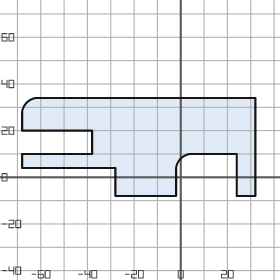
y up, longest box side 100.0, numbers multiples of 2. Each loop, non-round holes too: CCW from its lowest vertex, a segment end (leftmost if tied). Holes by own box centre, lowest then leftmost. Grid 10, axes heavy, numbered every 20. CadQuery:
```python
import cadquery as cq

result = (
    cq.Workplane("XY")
    .moveTo(-28.0, -8.0)
    .lineTo(-2.0, -8.0)
    .lineTo(-2.0, 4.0)
    .threePointArc((0.0, 8.0), (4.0, 10.0))
    .lineTo(24.0, 10.0)
    .lineTo(24.0, -8.0)
    .lineTo(32.0, -8.0)
    .lineTo(32.0, 34.0)
    .lineTo(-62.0, 34.0)
    .threePointArc((-66.0, 32.0), (-68.0, 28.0))
    .lineTo(-68.0, 20.0)
    .lineTo(-38.0, 20.0)
    .lineTo(-38.0, 10.0)
    .lineTo(-68.0, 10.0)
    .lineTo(-68.0, 4.0)
    .lineTo(-28.0, 4.0)
    .close()
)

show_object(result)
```